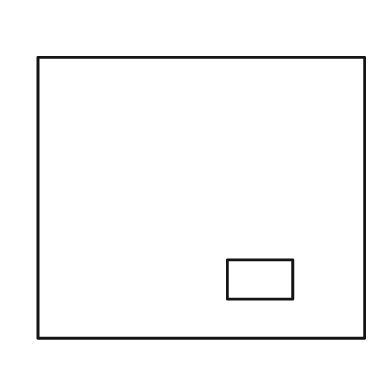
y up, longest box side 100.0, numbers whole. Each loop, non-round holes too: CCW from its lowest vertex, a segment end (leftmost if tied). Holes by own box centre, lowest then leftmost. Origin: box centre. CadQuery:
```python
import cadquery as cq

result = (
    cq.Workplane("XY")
    .moveTo(-50.0, -43.0)
    .lineTo(50.0, -43.0)
    .lineTo(50.0, 43.0)
    .lineTo(-50.0, 43.0)
    .close()
    .moveTo(8.0, -31.0)
    .lineTo(28.0, -31.0)
    .lineTo(28.0, -19.0)
    .lineTo(8.0, -19.0)
    .close()
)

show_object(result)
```